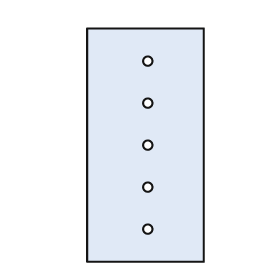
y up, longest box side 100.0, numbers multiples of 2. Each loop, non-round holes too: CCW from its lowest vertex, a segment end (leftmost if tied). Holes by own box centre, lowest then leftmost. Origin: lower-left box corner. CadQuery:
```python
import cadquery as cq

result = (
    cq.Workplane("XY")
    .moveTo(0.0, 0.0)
    .lineTo(50.0, 0.0)
    .lineTo(50.0, 100.0)
    .lineTo(0.0, 100.0)
    .close()
    .moveTo(26.0, 14.0)
    .circle(2.0)
    .moveTo(26.0, 32.0)
    .circle(2.0)
    .moveTo(26.0, 50.0)
    .circle(2.0)
    .moveTo(26.0, 68.0)
    .circle(2.0)
    .moveTo(26.0, 86.0)
    .circle(2.0)
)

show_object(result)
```